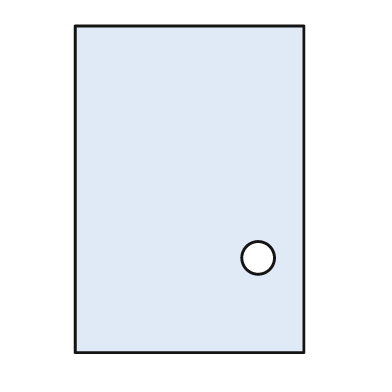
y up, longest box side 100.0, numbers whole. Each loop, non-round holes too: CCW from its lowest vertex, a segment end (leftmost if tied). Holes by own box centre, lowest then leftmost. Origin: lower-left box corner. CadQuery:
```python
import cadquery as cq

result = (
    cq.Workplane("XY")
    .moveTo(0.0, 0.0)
    .lineTo(70.0, 0.0)
    .lineTo(70.0, 100.0)
    .lineTo(0.0, 100.0)
    .close()
    .moveTo(56.0, 29.0)
    .circle(5.0)
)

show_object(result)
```